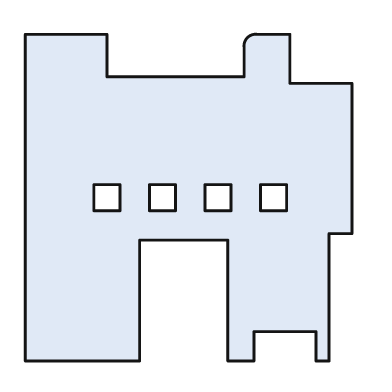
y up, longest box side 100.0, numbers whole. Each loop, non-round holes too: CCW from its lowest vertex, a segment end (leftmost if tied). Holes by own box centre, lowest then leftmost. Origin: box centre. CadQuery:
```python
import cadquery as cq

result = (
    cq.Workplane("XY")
    .moveTo(-50.0, -50.0)
    .lineTo(-15.0, -50.0)
    .lineTo(-15.0, -13.0)
    .lineTo(12.0, -13.0)
    .lineTo(12.0, -50.0)
    .lineTo(20.0, -50.0)
    .lineTo(20.0, -41.0)
    .lineTo(39.0, -41.0)
    .lineTo(39.0, -50.0)
    .lineTo(43.0, -50.0)
    .lineTo(43.0, -11.0)
    .lineTo(50.0, -11.0)
    .lineTo(50.0, 35.0)
    .lineTo(31.0, 35.0)
    .lineTo(31.0, 50.0)
    .lineTo(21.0, 50.0)
    .threePointArc((18.0, 49.0), (17.0, 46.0))
    .lineTo(17.0, 37.0)
    .lineTo(-25.0, 37.0)
    .lineTo(-25.0, 50.0)
    .lineTo(-50.0, 50.0)
    .close()
    .moveTo(-29.0, -4.0)
    .lineTo(-21.0, -4.0)
    .lineTo(-21.0, 4.0)
    .lineTo(-29.0, 4.0)
    .close()
    .moveTo(-12.0, -4.0)
    .lineTo(-4.0, -4.0)
    .lineTo(-4.0, 4.0)
    .lineTo(-12.0, 4.0)
    .close()
    .moveTo(5.0, -4.0)
    .lineTo(13.0, -4.0)
    .lineTo(13.0, 4.0)
    .lineTo(5.0, 4.0)
    .close()
    .moveTo(22.0, -4.0)
    .lineTo(30.0, -4.0)
    .lineTo(30.0, 4.0)
    .lineTo(22.0, 4.0)
    .close()
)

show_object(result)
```